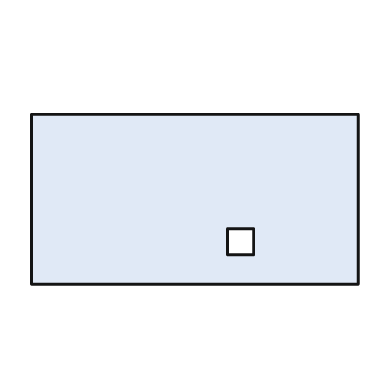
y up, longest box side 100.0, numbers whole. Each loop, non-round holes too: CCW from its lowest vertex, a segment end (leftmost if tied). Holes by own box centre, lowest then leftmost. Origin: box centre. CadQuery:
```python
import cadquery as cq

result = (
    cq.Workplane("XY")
    .moveTo(-50.0, -26.0)
    .lineTo(50.0, -26.0)
    .lineTo(50.0, 26.0)
    .lineTo(-50.0, 26.0)
    .close()
    .moveTo(10.0, -17.0)
    .lineTo(18.0, -17.0)
    .lineTo(18.0, -9.0)
    .lineTo(10.0, -9.0)
    .close()
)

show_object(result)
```